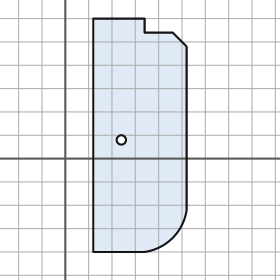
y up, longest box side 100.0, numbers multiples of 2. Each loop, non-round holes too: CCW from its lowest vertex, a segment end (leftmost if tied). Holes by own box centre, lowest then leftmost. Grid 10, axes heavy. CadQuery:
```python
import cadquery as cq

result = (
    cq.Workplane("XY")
    .moveTo(12.0, -40.0)
    .lineTo(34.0, -40.0)
    .threePointArc((46.0, -34.0), (52.0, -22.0))
    .lineTo(52.0, 48.0)
    .lineTo(46.0, 54.0)
    .lineTo(34.0, 54.0)
    .lineTo(34.0, 60.0)
    .lineTo(12.0, 60.0)
    .close()
    .moveTo(24.0, 8.0)
    .circle(2.0)
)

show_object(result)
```